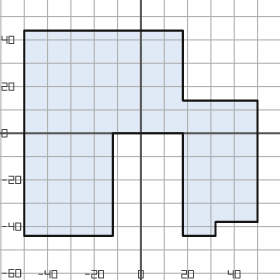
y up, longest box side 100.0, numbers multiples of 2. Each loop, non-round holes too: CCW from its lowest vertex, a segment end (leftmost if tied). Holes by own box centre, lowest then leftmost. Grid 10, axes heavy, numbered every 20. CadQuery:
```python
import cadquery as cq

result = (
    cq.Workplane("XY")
    .moveTo(-50.0, -44.0)
    .lineTo(-12.0, -44.0)
    .lineTo(-12.0, 0.0)
    .lineTo(18.0, 0.0)
    .lineTo(18.0, -44.0)
    .lineTo(32.0, -44.0)
    .lineTo(32.0, -38.0)
    .lineTo(50.0, -38.0)
    .lineTo(50.0, 14.0)
    .lineTo(18.0, 14.0)
    .lineTo(18.0, 44.0)
    .lineTo(-50.0, 44.0)
    .close()
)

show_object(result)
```